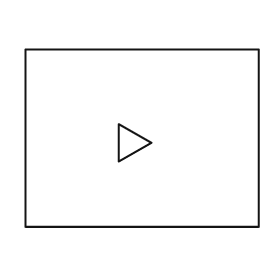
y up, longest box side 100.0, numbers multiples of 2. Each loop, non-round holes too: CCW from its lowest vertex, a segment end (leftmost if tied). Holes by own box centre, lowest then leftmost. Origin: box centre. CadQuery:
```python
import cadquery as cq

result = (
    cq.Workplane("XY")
    .moveTo(-50.0, -38.0)
    .lineTo(50.0, -38.0)
    .lineTo(50.0, 38.0)
    .lineTo(-50.0, 38.0)
    .close()
    .moveTo(-10.0, -10.0)
    .lineTo(4.0, -2.0)
    .lineTo(-10.0, 6.0)
    .close()
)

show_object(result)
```